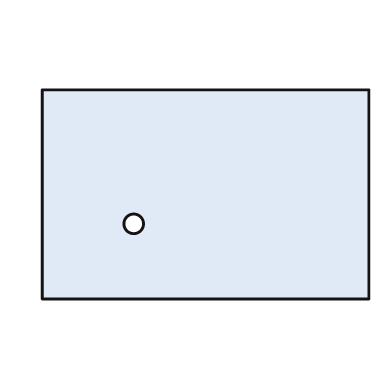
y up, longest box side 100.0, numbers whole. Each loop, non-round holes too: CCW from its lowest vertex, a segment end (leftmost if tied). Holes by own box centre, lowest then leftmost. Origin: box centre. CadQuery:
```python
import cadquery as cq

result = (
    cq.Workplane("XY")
    .moveTo(-50.0, -32.0)
    .lineTo(50.0, -32.0)
    .lineTo(50.0, 32.0)
    .lineTo(-50.0, 32.0)
    .close()
    .moveTo(-22.0, -9.0)
    .circle(3.0)
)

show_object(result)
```